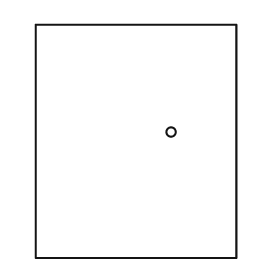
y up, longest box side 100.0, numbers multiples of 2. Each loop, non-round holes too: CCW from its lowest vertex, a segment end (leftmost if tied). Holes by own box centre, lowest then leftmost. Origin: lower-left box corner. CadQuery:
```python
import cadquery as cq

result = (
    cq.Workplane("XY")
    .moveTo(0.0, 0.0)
    .lineTo(86.0, 0.0)
    .lineTo(86.0, 100.0)
    .lineTo(0.0, 100.0)
    .close()
    .moveTo(58.0, 54.0)
    .circle(2.0)
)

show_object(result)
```